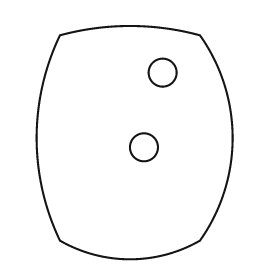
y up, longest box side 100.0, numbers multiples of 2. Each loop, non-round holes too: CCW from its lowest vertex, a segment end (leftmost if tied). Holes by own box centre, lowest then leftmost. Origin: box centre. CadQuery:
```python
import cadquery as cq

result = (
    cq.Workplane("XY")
    .moveTo(-32.0, -42.0)
    .threePointArc((-2.0, -50.0), (28.0, -42.0))
    .threePointArc((42.0, 2.0), (28.0, 46.0))
    .threePointArc((-2.0, 50.0), (-32.0, 46.0))
    .threePointArc((-42.0, 2.0), (-32.0, -42.0))
    .close()
    .moveTo(4.0, -2.0)
    .circle(6.0)
    .moveTo(12.0, 30.0)
    .circle(6.0)
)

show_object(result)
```